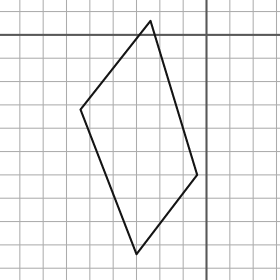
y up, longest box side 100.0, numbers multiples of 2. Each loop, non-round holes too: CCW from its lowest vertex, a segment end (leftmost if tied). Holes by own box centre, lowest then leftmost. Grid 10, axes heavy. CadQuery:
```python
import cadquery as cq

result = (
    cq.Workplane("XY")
    .moveTo(-30.0, -94.0)
    .lineTo(-4.0, -60.0)
    .lineTo(-24.0, 6.0)
    .lineTo(-54.0, -32.0)
    .close()
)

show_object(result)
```